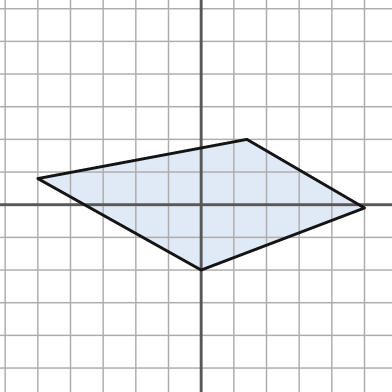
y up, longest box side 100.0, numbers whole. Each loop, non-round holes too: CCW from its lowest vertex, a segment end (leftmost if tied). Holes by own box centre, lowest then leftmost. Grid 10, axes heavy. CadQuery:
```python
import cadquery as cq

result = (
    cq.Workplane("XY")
    .moveTo(0.0, -20.0)
    .lineTo(50.0, -1.0)
    .lineTo(14.0, 20.0)
    .lineTo(-50.0, 8.0)
    .close()
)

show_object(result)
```